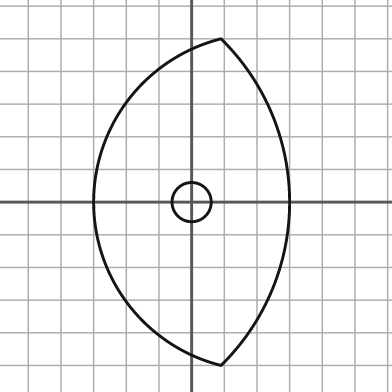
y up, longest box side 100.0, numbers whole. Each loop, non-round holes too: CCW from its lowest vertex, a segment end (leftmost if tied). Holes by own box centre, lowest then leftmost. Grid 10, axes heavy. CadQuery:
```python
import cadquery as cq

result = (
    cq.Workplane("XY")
    .moveTo(9.0, -50.0)
    .threePointArc((30.0, 0.0), (9.0, 50.0))
    .threePointArc((-30.0, 0.0), (9.0, -50.0))
    .close()
    .moveTo(0.0, 0.0)
    .circle(6.0)
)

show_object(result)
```